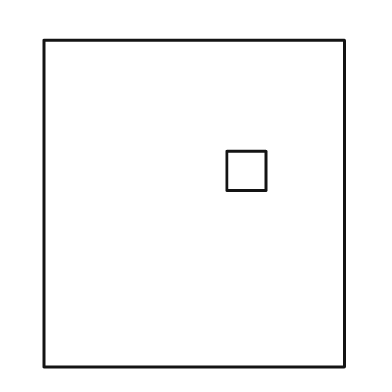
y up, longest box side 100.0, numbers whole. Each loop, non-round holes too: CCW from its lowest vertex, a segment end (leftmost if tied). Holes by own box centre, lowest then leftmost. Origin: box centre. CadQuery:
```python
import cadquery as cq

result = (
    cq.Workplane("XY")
    .moveTo(-46.0, -50.0)
    .lineTo(46.0, -50.0)
    .lineTo(46.0, 50.0)
    .lineTo(-46.0, 50.0)
    .close()
    .moveTo(10.0, 4.0)
    .lineTo(22.0, 4.0)
    .lineTo(22.0, 16.0)
    .lineTo(10.0, 16.0)
    .close()
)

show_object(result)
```